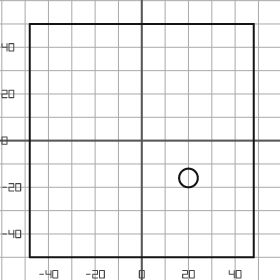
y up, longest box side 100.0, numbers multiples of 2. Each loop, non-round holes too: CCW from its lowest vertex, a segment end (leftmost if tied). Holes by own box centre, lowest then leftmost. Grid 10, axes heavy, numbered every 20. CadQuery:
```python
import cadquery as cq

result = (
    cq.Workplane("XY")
    .moveTo(-48.0, -50.0)
    .lineTo(48.0, -50.0)
    .lineTo(48.0, 50.0)
    .lineTo(-48.0, 50.0)
    .close()
    .moveTo(20.0, -16.0)
    .circle(4.0)
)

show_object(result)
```